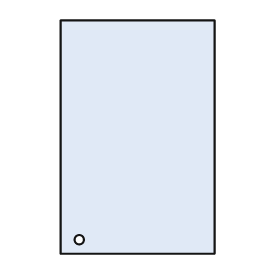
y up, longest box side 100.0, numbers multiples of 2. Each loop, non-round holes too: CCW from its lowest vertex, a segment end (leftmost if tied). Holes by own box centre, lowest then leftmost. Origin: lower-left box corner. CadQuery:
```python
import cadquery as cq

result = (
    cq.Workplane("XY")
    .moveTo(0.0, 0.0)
    .lineTo(66.0, 0.0)
    .lineTo(66.0, 100.0)
    .lineTo(0.0, 100.0)
    .close()
    .moveTo(8.0, 6.0)
    .circle(2.0)
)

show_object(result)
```